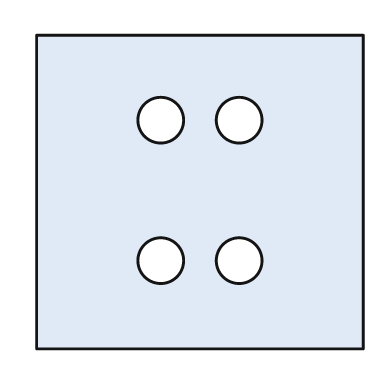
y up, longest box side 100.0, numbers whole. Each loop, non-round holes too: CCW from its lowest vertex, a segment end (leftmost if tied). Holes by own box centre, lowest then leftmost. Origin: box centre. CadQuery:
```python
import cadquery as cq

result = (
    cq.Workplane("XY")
    .moveTo(-50.0, -48.0)
    .lineTo(50.0, -48.0)
    .lineTo(50.0, 48.0)
    .lineTo(-50.0, 48.0)
    .close()
    .moveTo(-12.0, -21.0)
    .circle(7.0)
    .moveTo(12.0, -21.0)
    .circle(7.0)
    .moveTo(-12.0, 22.0)
    .circle(7.0)
    .moveTo(12.0, 22.0)
    .circle(7.0)
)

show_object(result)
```